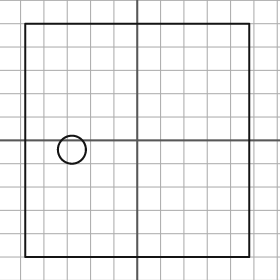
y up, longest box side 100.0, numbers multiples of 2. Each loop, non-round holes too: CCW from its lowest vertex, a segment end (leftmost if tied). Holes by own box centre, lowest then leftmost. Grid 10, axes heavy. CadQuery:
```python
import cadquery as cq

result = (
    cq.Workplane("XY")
    .moveTo(-48.0, -50.0)
    .lineTo(48.0, -50.0)
    .lineTo(48.0, 50.0)
    .lineTo(-48.0, 50.0)
    .close()
    .moveTo(-28.0, -4.0)
    .circle(6.0)
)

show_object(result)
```